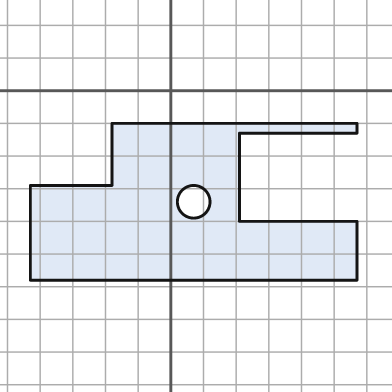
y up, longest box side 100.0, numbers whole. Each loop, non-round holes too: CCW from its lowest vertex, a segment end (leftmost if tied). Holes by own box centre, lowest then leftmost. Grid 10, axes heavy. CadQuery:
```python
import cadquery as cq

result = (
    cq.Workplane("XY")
    .moveTo(-43.0, -58.0)
    .lineTo(57.0, -58.0)
    .lineTo(57.0, -40.0)
    .lineTo(21.0, -40.0)
    .lineTo(21.0, -13.0)
    .lineTo(57.0, -13.0)
    .lineTo(57.0, -10.0)
    .lineTo(-18.0, -10.0)
    .lineTo(-18.0, -29.0)
    .lineTo(-43.0, -29.0)
    .close()
    .moveTo(7.0, -34.0)
    .circle(5.0)
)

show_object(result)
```